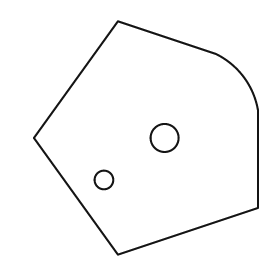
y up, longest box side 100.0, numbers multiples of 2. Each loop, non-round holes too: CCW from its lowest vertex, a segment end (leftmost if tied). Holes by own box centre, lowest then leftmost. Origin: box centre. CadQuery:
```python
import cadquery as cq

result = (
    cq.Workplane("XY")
    .moveTo(-12.0, -50.0)
    .lineTo(48.0, -30.0)
    .lineTo(48.0, 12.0)
    .threePointArc((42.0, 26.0), (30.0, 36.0))
    .lineTo(-12.0, 50.0)
    .lineTo(-48.0, 0.0)
    .close()
    .moveTo(-18.0, -18.0)
    .circle(4.0)
    .moveTo(8.0, 0.0)
    .circle(6.0)
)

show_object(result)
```